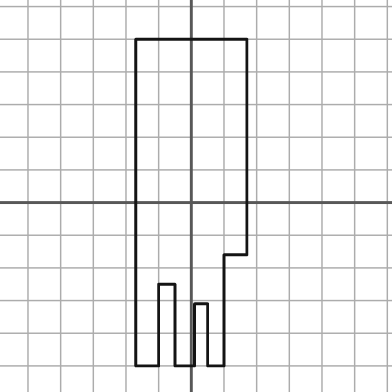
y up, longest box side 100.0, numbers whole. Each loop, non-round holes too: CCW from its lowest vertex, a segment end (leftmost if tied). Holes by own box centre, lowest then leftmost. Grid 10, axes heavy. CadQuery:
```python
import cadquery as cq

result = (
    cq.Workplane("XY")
    .moveTo(-17.0, -50.0)
    .lineTo(-10.0, -50.0)
    .lineTo(-10.0, -25.0)
    .lineTo(-5.0, -25.0)
    .lineTo(-5.0, -50.0)
    .lineTo(1.0, -50.0)
    .lineTo(1.0, -31.0)
    .lineTo(5.0, -31.0)
    .lineTo(5.0, -50.0)
    .lineTo(10.0, -50.0)
    .lineTo(10.0, -16.0)
    .lineTo(17.0, -16.0)
    .lineTo(17.0, 50.0)
    .lineTo(-17.0, 50.0)
    .close()
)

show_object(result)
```